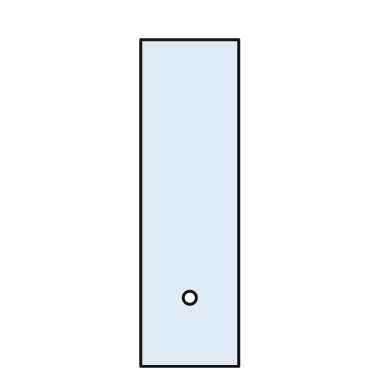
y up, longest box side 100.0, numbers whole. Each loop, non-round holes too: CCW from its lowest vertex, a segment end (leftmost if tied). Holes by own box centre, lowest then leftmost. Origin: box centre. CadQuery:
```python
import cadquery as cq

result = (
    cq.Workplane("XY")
    .moveTo(-15.0, -50.0)
    .lineTo(15.0, -50.0)
    .lineTo(15.0, 50.0)
    .lineTo(-15.0, 50.0)
    .close()
    .moveTo(0.0, -29.0)
    .circle(2.0)
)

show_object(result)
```